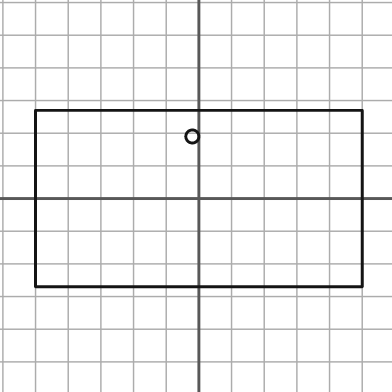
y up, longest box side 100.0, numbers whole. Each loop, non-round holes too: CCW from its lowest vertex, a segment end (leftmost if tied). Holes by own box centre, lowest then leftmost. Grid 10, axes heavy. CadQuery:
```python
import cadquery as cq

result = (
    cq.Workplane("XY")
    .moveTo(-50.0, -27.0)
    .lineTo(50.0, -27.0)
    .lineTo(50.0, 27.0)
    .lineTo(-50.0, 27.0)
    .close()
    .moveTo(-2.0, 19.0)
    .circle(2.0)
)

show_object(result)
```